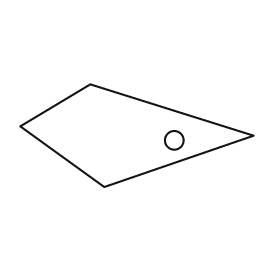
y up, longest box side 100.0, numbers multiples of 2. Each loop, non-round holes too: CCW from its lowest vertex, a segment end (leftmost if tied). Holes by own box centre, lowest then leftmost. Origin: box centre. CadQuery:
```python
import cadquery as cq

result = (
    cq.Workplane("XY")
    .moveTo(-14.0, -22.0)
    .lineTo(50.0, 0.0)
    .lineTo(-20.0, 22.0)
    .lineTo(-50.0, 4.0)
    .close()
    .moveTo(16.0, -2.0)
    .circle(4.0)
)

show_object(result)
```